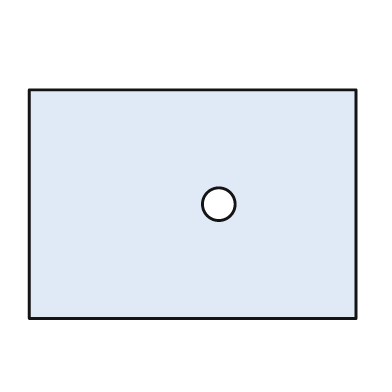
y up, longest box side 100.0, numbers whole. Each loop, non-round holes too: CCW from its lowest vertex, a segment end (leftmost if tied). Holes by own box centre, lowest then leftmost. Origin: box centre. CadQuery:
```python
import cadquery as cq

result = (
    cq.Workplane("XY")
    .moveTo(-50.0, -35.0)
    .lineTo(50.0, -35.0)
    .lineTo(50.0, 35.0)
    .lineTo(-50.0, 35.0)
    .close()
    .moveTo(8.0, 0.0)
    .circle(5.0)
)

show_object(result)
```